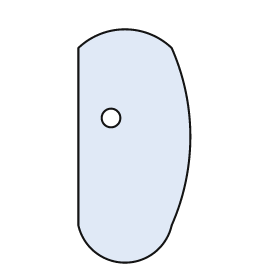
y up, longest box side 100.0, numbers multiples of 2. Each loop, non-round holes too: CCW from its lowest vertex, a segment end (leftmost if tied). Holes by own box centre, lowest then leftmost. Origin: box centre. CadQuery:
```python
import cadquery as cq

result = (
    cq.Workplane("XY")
    .moveTo(-24.0, -34.0)
    .threePointArc((-4.0, -50.0), (16.0, -34.0))
    .threePointArc((24.0, 4.0), (16.0, 42.0))
    .threePointArc((-4.0, 50.0), (-24.0, 42.0))
    .close()
    .moveTo(-10.0, 12.0)
    .circle(4.0)
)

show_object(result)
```